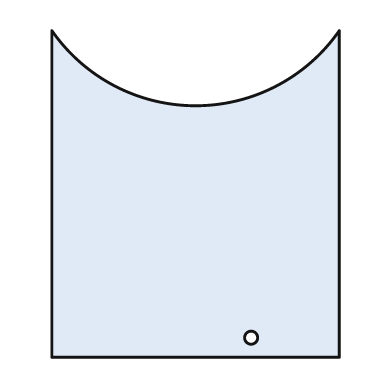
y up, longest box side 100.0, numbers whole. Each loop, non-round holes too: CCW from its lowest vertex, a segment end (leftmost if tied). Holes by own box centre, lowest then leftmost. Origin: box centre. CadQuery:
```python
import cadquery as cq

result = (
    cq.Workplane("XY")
    .moveTo(-44.0, -50.0)
    .lineTo(44.0, -50.0)
    .lineTo(44.0, 50.0)
    .threePointArc((0.0, 27.0), (-44.0, 50.0))
    .close()
    .moveTo(17.0, -44.0)
    .circle(2.0)
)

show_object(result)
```